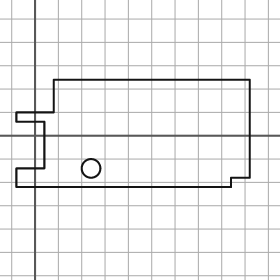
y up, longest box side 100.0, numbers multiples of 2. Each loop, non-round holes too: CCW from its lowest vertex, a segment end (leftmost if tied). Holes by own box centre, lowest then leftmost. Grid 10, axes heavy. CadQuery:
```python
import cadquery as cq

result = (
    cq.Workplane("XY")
    .moveTo(-8.0, -22.0)
    .lineTo(84.0, -22.0)
    .lineTo(84.0, -18.0)
    .lineTo(92.0, -18.0)
    .lineTo(92.0, 24.0)
    .lineTo(8.0, 24.0)
    .lineTo(8.0, 10.0)
    .lineTo(-8.0, 10.0)
    .lineTo(-8.0, 6.0)
    .lineTo(4.0, 6.0)
    .lineTo(4.0, -14.0)
    .lineTo(-8.0, -14.0)
    .close()
    .moveTo(24.0, -14.0)
    .circle(4.0)
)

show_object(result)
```